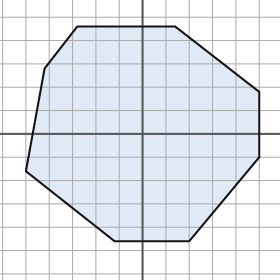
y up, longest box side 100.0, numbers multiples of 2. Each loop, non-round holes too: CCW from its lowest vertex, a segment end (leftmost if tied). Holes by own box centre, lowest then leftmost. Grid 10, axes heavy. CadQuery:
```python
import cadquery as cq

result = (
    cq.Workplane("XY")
    .moveTo(-12.0, -46.0)
    .lineTo(20.0, -46.0)
    .lineTo(50.0, -10.0)
    .lineTo(50.0, 18.0)
    .lineTo(14.0, 46.0)
    .lineTo(-28.0, 46.0)
    .lineTo(-42.0, 28.0)
    .lineTo(-50.0, -16.0)
    .close()
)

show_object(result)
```